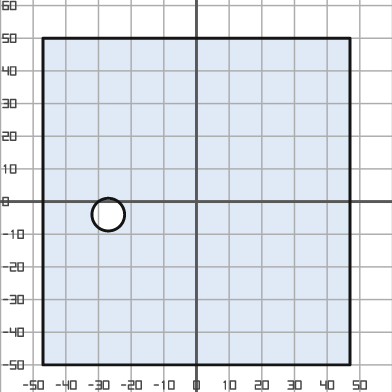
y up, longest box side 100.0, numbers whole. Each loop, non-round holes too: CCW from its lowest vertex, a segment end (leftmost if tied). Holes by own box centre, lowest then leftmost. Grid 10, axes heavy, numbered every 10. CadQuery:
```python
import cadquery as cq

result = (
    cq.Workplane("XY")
    .moveTo(-47.0, -50.0)
    .lineTo(47.0, -50.0)
    .lineTo(47.0, 50.0)
    .lineTo(-47.0, 50.0)
    .close()
    .moveTo(-27.0, -4.0)
    .circle(5.0)
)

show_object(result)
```